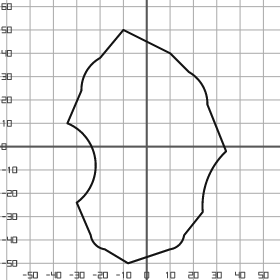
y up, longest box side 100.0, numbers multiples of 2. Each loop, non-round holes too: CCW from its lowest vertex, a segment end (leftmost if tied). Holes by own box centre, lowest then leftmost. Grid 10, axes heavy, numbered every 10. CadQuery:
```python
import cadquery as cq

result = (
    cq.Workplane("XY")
    .moveTo(-8.0, -50.0)
    .lineTo(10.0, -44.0)
    .threePointArc((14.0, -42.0), (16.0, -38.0))
    .lineTo(24.0, -28.0)
    .threePointArc((26.0, -14.0), (34.0, -2.0))
    .lineTo(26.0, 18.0)
    .threePointArc((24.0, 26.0), (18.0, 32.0))
    .lineTo(10.0, 40.0)
    .lineTo(-10.0, 50.0)
    .lineTo(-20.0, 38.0)
    .threePointArc((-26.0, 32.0), (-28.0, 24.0))
    .lineTo(-34.0, 10.0)
    .threePointArc((-22.0, -6.0), (-30.0, -24.0))
    .lineTo(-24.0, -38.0)
    .threePointArc((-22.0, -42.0), (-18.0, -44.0))
    .close()
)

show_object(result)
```